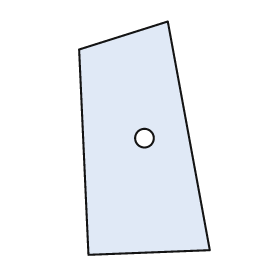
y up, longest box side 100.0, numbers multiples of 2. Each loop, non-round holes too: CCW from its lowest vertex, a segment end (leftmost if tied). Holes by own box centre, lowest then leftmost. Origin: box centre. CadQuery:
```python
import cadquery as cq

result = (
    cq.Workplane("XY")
    .moveTo(-24.0, -50.0)
    .lineTo(28.0, -48.0)
    .lineTo(10.0, 50.0)
    .lineTo(-28.0, 38.0)
    .close()
    .moveTo(0.0, 0.0)
    .circle(4.0)
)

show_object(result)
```